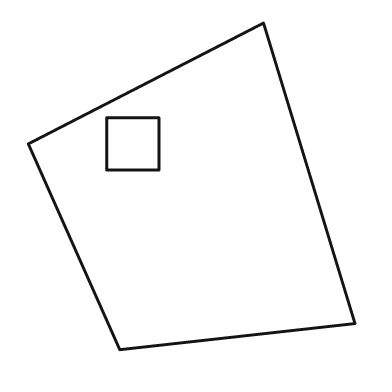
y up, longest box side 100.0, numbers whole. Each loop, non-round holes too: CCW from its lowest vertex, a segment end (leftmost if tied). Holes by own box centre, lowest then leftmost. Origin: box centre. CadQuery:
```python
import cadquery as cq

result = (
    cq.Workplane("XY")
    .moveTo(-22.0, -50.0)
    .lineTo(50.0, -42.0)
    .lineTo(22.0, 50.0)
    .lineTo(-50.0, 13.0)
    .close()
    .moveTo(-26.0, 5.0)
    .lineTo(-10.0, 5.0)
    .lineTo(-10.0, 21.0)
    .lineTo(-26.0, 21.0)
    .close()
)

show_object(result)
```